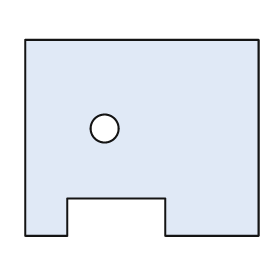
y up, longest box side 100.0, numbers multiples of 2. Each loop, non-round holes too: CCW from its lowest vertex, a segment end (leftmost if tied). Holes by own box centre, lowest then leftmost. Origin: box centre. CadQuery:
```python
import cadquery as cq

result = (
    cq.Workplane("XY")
    .moveTo(-50.0, -42.0)
    .lineTo(-32.0, -42.0)
    .lineTo(-32.0, -26.0)
    .lineTo(10.0, -26.0)
    .lineTo(10.0, -42.0)
    .lineTo(50.0, -42.0)
    .lineTo(50.0, 42.0)
    .lineTo(-50.0, 42.0)
    .close()
    .moveTo(-16.0, 4.0)
    .circle(6.0)
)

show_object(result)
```